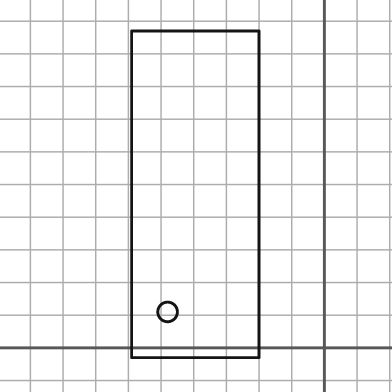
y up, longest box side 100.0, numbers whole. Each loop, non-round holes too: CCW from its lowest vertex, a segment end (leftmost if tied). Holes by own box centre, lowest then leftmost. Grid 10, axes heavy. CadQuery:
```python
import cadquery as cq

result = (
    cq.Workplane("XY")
    .moveTo(-59.0, -3.0)
    .lineTo(-20.0, -3.0)
    .lineTo(-20.0, 97.0)
    .lineTo(-59.0, 97.0)
    .close()
    .moveTo(-48.0, 11.0)
    .circle(3.0)
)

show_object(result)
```